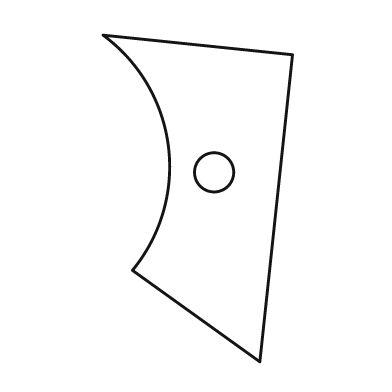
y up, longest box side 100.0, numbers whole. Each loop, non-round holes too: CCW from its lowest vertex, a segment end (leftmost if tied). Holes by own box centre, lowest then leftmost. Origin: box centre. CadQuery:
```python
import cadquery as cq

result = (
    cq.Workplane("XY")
    .moveTo(19.0, -50.0)
    .lineTo(29.0, 44.0)
    .lineTo(-29.0, 50.0)
    .threePointArc((-9.0, 16.0), (-20.0, -22.0))
    .close()
    .moveTo(5.0, 8.0)
    .circle(6.0)
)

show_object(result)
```